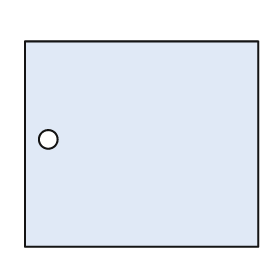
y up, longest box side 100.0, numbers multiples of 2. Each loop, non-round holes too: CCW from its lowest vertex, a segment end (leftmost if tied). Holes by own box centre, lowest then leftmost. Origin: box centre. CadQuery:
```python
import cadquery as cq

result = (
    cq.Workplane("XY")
    .moveTo(-50.0, -44.0)
    .lineTo(50.0, -44.0)
    .lineTo(50.0, 44.0)
    .lineTo(-50.0, 44.0)
    .close()
    .moveTo(-40.0, 2.0)
    .circle(4.0)
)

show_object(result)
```